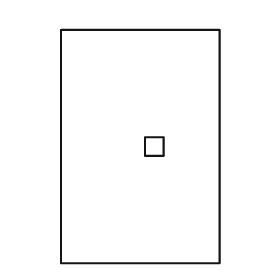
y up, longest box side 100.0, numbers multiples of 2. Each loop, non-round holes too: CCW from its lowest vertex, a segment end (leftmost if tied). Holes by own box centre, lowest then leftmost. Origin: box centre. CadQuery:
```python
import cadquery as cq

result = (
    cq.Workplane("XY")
    .moveTo(-34.0, -50.0)
    .lineTo(34.0, -50.0)
    .lineTo(34.0, 50.0)
    .lineTo(-34.0, 50.0)
    .close()
    .moveTo(2.0, -4.0)
    .lineTo(10.0, -4.0)
    .lineTo(10.0, 4.0)
    .lineTo(2.0, 4.0)
    .close()
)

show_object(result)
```